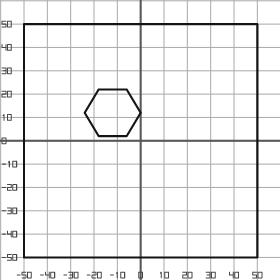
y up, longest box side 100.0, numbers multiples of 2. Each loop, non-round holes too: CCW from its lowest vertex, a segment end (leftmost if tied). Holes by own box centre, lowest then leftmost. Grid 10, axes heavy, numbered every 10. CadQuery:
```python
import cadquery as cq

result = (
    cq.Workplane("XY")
    .moveTo(-50.0, -50.0)
    .lineTo(50.0, -50.0)
    .lineTo(50.0, 50.0)
    .lineTo(-50.0, 50.0)
    .close()
    .moveTo(-18.0, 2.0)
    .lineTo(-6.0, 2.0)
    .lineTo(0.0, 12.0)
    .lineTo(-6.0, 22.0)
    .lineTo(-18.0, 22.0)
    .lineTo(-24.0, 12.0)
    .close()
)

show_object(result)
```